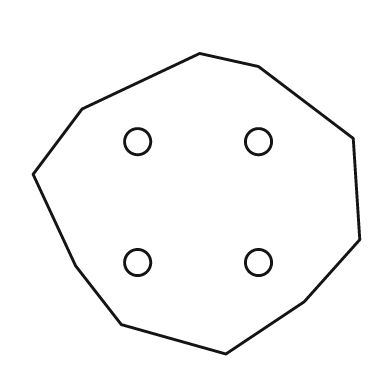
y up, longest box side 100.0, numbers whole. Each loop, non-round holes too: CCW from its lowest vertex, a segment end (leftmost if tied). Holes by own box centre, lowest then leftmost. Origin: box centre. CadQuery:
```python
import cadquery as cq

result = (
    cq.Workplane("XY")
    .moveTo(9.0, -46.0)
    .lineTo(33.0, -30.0)
    .lineTo(50.0, -11.0)
    .lineTo(48.0, 20.0)
    .lineTo(19.0, 42.0)
    .lineTo(1.0, 46.0)
    .lineTo(-35.0, 29.0)
    .lineTo(-50.0, 9.0)
    .lineTo(-37.0, -19.0)
    .lineTo(-23.0, -37.0)
    .close()
    .moveTo(-18.0, -18.0)
    .circle(4.0)
    .moveTo(19.0, -18.0)
    .circle(4.0)
    .moveTo(-18.0, 19.0)
    .circle(4.0)
    .moveTo(19.0, 19.0)
    .circle(4.0)
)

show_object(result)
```